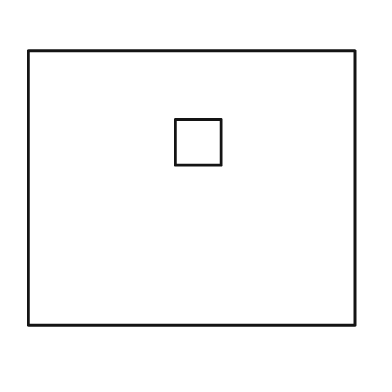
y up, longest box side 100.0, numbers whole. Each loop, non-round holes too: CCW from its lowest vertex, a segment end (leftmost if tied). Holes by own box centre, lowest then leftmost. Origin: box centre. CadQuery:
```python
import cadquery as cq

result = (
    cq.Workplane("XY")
    .moveTo(-50.0, -42.0)
    .lineTo(50.0, -42.0)
    .lineTo(50.0, 42.0)
    .lineTo(-50.0, 42.0)
    .close()
    .moveTo(-5.0, 7.0)
    .lineTo(9.0, 7.0)
    .lineTo(9.0, 21.0)
    .lineTo(-5.0, 21.0)
    .close()
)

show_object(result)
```